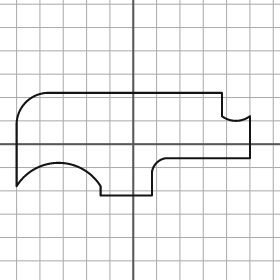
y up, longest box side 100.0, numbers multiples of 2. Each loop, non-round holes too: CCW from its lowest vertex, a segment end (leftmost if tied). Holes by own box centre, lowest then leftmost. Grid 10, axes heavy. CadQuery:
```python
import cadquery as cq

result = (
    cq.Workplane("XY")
    .moveTo(-14.0, -22.0)
    .lineTo(8.0, -22.0)
    .lineTo(8.0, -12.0)
    .threePointArc((10.0, -8.0), (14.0, -6.0))
    .lineTo(50.0, -6.0)
    .lineTo(50.0, 12.0)
    .threePointArc((44.0, 10.0), (38.0, 12.0))
    .lineTo(38.0, 22.0)
    .lineTo(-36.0, 22.0)
    .threePointArc((-46.0, 18.0), (-50.0, 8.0))
    .lineTo(-50.0, -18.0)
    .threePointArc((-32.0, -8.0), (-14.0, -18.0))
    .close()
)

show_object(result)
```